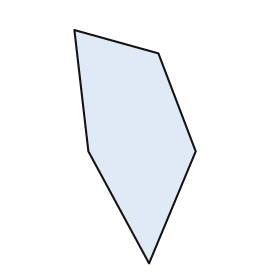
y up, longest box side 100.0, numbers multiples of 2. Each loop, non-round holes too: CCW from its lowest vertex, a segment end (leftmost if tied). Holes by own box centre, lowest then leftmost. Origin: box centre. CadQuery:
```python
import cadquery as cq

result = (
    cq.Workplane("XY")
    .moveTo(6.0, -50.0)
    .lineTo(26.0, -2.0)
    .lineTo(10.0, 40.0)
    .lineTo(-26.0, 50.0)
    .lineTo(-20.0, -2.0)
    .close()
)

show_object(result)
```